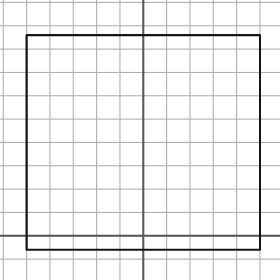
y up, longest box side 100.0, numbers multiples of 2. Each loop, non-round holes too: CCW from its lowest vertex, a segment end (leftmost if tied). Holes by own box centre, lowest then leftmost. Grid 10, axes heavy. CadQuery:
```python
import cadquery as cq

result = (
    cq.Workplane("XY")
    .moveTo(-50.0, -6.0)
    .lineTo(50.0, -6.0)
    .lineTo(50.0, 86.0)
    .lineTo(-50.0, 86.0)
    .close()
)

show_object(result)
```